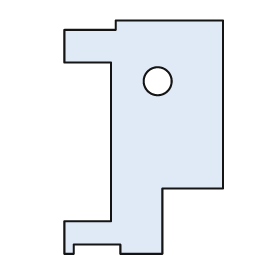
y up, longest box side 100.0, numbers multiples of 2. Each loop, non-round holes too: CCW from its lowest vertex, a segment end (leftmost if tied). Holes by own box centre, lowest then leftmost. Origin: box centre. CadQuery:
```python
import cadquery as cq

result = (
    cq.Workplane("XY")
    .moveTo(-34.0, -50.0)
    .lineTo(-30.0, -50.0)
    .lineTo(-30.0, -46.0)
    .lineTo(-10.0, -46.0)
    .lineTo(-10.0, -50.0)
    .lineTo(8.0, -50.0)
    .lineTo(8.0, -22.0)
    .lineTo(34.0, -22.0)
    .lineTo(34.0, 50.0)
    .lineTo(-12.0, 50.0)
    .lineTo(-12.0, 46.0)
    .lineTo(-34.0, 46.0)
    .lineTo(-34.0, 32.0)
    .lineTo(-14.0, 32.0)
    .lineTo(-14.0, -36.0)
    .lineTo(-34.0, -36.0)
    .close()
    .moveTo(6.0, 24.0)
    .circle(6.0)
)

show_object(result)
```